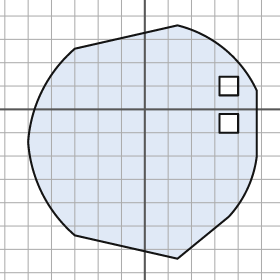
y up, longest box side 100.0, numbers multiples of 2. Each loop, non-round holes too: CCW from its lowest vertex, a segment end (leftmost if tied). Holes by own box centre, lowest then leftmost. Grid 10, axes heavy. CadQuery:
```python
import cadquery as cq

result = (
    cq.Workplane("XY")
    .moveTo(14.0, -64.0)
    .lineTo(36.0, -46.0)
    .threePointArc((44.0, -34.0), (48.0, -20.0))
    .lineTo(48.0, 8.0)
    .threePointArc((34.0, 26.0), (14.0, 36.0))
    .lineTo(-30.0, 26.0)
    .threePointArc((-44.0, 8.0), (-50.0, -14.0))
    .threePointArc((-44.0, -36.0), (-30.0, -54.0))
    .close()
    .moveTo(32.0, -10.0)
    .lineTo(40.0, -10.0)
    .lineTo(40.0, -2.0)
    .lineTo(32.0, -2.0)
    .close()
    .moveTo(32.0, 6.0)
    .lineTo(40.0, 6.0)
    .lineTo(40.0, 14.0)
    .lineTo(32.0, 14.0)
    .close()
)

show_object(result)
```